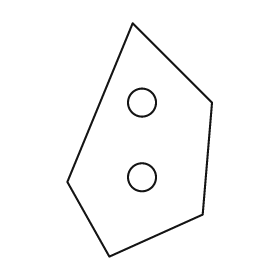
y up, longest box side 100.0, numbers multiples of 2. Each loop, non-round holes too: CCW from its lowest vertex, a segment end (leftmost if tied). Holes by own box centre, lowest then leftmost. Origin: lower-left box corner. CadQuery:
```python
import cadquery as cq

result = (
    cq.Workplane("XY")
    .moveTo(18.0, 0.0)
    .lineTo(58.0, 18.0)
    .lineTo(62.0, 66.0)
    .lineTo(28.0, 100.0)
    .lineTo(0.0, 32.0)
    .close()
    .moveTo(32.0, 34.0)
    .circle(6.0)
    .moveTo(32.0, 66.0)
    .circle(6.0)
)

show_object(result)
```